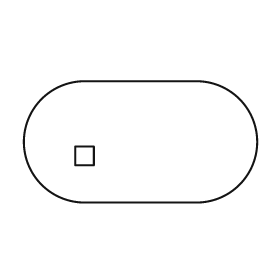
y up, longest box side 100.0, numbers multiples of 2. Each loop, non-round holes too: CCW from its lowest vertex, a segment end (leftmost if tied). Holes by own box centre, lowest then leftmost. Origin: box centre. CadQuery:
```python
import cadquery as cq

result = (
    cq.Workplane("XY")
    .moveTo(-24.0, -26.0)
    .lineTo(24.0, -26.0)
    .threePointArc((50.0, 0.0), (24.0, 26.0))
    .lineTo(-24.0, 26.0)
    .threePointArc((-50.0, 0.0), (-24.0, -26.0))
    .close()
    .moveTo(-28.0, -10.0)
    .lineTo(-20.0, -10.0)
    .lineTo(-20.0, -2.0)
    .lineTo(-28.0, -2.0)
    .close()
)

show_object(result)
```